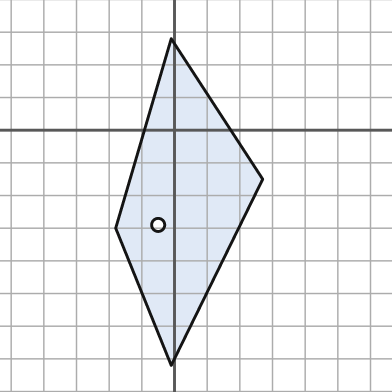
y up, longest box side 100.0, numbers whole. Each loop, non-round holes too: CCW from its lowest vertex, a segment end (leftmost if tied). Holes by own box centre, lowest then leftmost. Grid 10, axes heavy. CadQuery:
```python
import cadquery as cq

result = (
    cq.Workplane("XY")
    .moveTo(-1.0, -72.0)
    .lineTo(27.0, -15.0)
    .lineTo(-1.0, 28.0)
    .lineTo(-18.0, -30.0)
    .close()
    .moveTo(-5.0, -29.0)
    .circle(2.0)
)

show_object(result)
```